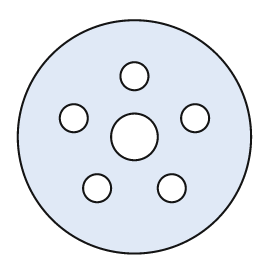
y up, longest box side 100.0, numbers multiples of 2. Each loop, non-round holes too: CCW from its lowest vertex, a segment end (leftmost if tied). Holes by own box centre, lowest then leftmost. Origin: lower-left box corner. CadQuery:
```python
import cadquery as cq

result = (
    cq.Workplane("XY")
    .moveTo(50.0, 50.0)
    .circle(50.0)
    .moveTo(34.0, 28.0)
    .circle(6.0)
    .moveTo(66.0, 28.0)
    .circle(6.0)
    .moveTo(50.0, 50.0)
    .circle(10.0)
    .moveTo(24.0, 58.0)
    .circle(6.0)
    .moveTo(76.0, 58.0)
    .circle(6.0)
    .moveTo(50.0, 76.0)
    .circle(6.0)
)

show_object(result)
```